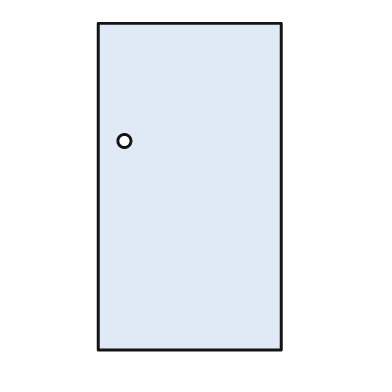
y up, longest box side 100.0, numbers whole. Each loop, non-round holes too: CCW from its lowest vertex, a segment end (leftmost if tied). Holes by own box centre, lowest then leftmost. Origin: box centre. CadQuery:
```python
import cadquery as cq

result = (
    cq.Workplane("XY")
    .moveTo(-28.0, -50.0)
    .lineTo(28.0, -50.0)
    .lineTo(28.0, 50.0)
    .lineTo(-28.0, 50.0)
    .close()
    .moveTo(-20.0, 14.0)
    .circle(2.0)
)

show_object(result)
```